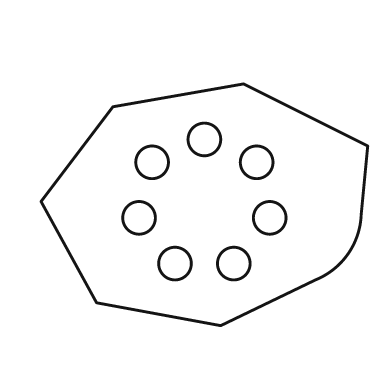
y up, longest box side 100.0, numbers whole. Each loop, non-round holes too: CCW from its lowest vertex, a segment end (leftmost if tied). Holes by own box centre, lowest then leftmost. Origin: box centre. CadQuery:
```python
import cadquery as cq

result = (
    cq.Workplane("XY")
    .moveTo(5.0, -37.0)
    .lineTo(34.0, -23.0)
    .threePointArc((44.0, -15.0), (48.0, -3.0))
    .lineTo(50.0, 18.0)
    .lineTo(12.0, 37.0)
    .lineTo(-28.0, 30.0)
    .lineTo(-50.0, 1.0)
    .lineTo(-33.0, -30.0)
    .close()
    .moveTo(-9.0, -18.0)
    .circle(5.0)
    .moveTo(9.0, -18.0)
    .circle(5.0)
    .moveTo(-20.0, -4.0)
    .circle(5.0)
    .moveTo(20.0, -4.0)
    .circle(5.0)
    .moveTo(-16.0, 13.0)
    .circle(5.0)
    .moveTo(16.0, 13.0)
    .circle(5.0)
    .moveTo(0.0, 20.0)
    .circle(5.0)
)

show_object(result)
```